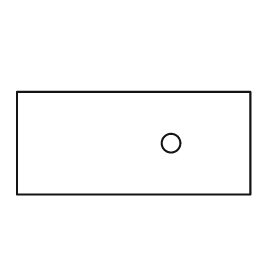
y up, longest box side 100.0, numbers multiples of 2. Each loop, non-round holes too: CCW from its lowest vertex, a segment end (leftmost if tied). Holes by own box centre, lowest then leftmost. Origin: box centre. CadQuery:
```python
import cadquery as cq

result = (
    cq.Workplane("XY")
    .moveTo(-50.0, -22.0)
    .lineTo(50.0, -22.0)
    .lineTo(50.0, 22.0)
    .lineTo(-50.0, 22.0)
    .close()
    .moveTo(16.0, 0.0)
    .circle(4.0)
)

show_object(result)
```